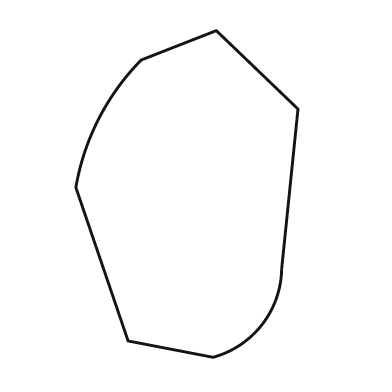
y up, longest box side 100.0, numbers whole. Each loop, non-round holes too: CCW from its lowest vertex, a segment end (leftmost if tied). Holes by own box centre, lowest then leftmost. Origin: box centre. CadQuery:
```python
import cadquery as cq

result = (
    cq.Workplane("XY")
    .moveTo(8.0, -50.0)
    .threePointArc((23.0, -40.0), (29.0, -23.0))
    .lineTo(34.0, 26.0)
    .lineTo(9.0, 50.0)
    .lineTo(-14.0, 41.0)
    .threePointArc((-27.0, 23.0), (-34.0, 2.0))
    .lineTo(-18.0, -45.0)
    .close()
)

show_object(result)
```